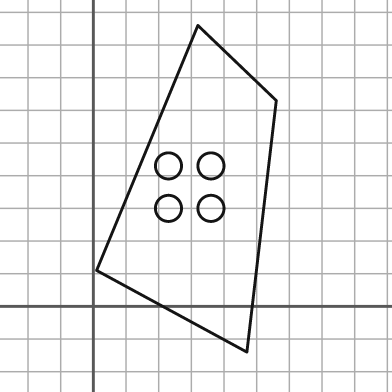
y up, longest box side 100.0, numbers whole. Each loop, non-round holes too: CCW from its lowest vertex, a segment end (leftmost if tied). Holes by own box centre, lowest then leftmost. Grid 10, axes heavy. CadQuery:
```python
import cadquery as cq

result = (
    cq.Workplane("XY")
    .moveTo(47.0, -14.0)
    .lineTo(56.0, 63.0)
    .lineTo(32.0, 86.0)
    .lineTo(1.0, 11.0)
    .close()
    .moveTo(23.0, 30.0)
    .circle(4.0)
    .moveTo(36.0, 30.0)
    .circle(4.0)
    .moveTo(23.0, 43.0)
    .circle(4.0)
    .moveTo(36.0, 43.0)
    .circle(4.0)
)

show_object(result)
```